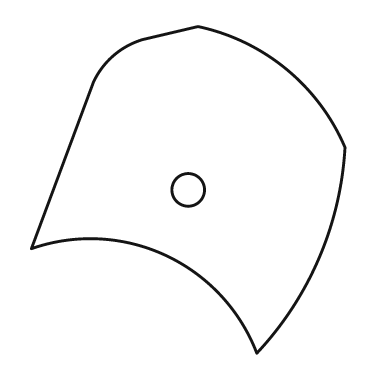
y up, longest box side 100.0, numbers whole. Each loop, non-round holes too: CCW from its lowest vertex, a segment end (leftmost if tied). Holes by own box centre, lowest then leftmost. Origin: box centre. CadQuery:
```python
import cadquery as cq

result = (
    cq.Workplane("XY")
    .moveTo(21.0, -50.0)
    .threePointArc((40.0, -21.0), (48.0, 13.0))
    .threePointArc((30.0, 37.0), (3.0, 50.0))
    .lineTo(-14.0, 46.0)
    .threePointArc((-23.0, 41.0), (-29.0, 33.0))
    .lineTo(-48.0, -18.0)
    .threePointArc((-7.0, -20.0), (21.0, -50.0))
    .close()
    .moveTo(0.0, 0.0)
    .circle(5.0)
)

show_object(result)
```